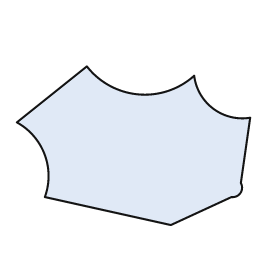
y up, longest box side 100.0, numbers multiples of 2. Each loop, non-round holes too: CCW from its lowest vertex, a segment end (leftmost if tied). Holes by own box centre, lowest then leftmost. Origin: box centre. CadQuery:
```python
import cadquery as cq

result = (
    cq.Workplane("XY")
    .moveTo(16.0, -34.0)
    .lineTo(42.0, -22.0)
    .threePointArc((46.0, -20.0), (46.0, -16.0))
    .lineTo(50.0, 12.0)
    .threePointArc((34.0, 16.0), (26.0, 30.0))
    .threePointArc((2.0, 22.0), (-20.0, 34.0))
    .lineTo(-50.0, 10.0)
    .threePointArc((-38.0, -4.0), (-38.0, -22.0))
    .close()
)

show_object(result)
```